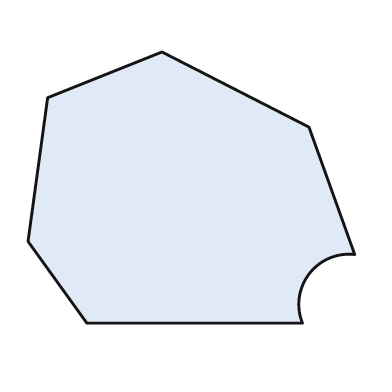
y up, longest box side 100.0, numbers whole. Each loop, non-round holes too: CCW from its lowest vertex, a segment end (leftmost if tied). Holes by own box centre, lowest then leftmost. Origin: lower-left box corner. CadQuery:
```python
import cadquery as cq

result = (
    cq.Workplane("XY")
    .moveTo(18.0, 0.0)
    .lineTo(84.0, 0.0)
    .threePointArc((86.0, 15.0), (100.0, 21.0))
    .lineTo(86.0, 60.0)
    .lineTo(41.0, 83.0)
    .lineTo(6.0, 69.0)
    .lineTo(0.0, 25.0)
    .close()
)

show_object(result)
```